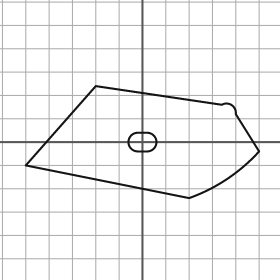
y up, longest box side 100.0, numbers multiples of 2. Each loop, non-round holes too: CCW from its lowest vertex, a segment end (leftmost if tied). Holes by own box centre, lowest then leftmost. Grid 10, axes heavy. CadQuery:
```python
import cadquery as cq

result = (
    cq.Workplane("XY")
    .moveTo(20.0, -24.0)
    .threePointArc((36.0, -16.0), (50.0, -4.0))
    .lineTo(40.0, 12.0)
    .threePointArc((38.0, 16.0), (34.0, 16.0))
    .lineTo(-20.0, 24.0)
    .lineTo(-50.0, -10.0)
    .close()
    .moveTo(-2.0, -4.0)
    .lineTo(2.0, -4.0)
    .threePointArc((6.0, 0.0), (2.0, 4.0))
    .lineTo(-2.0, 4.0)
    .threePointArc((-6.0, 0.0), (-2.0, -4.0))
    .close()
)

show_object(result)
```